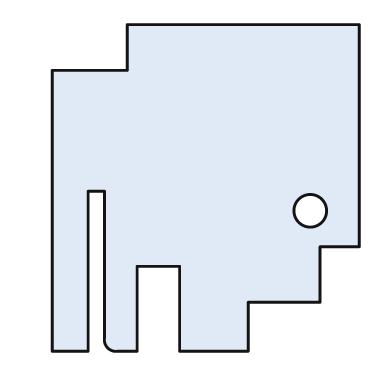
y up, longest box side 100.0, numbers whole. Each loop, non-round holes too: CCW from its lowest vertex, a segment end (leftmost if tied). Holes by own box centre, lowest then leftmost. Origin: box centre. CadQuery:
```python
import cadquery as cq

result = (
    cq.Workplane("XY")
    .moveTo(-47.0, -50.0)
    .lineTo(-36.0, -50.0)
    .lineTo(-36.0, -1.0)
    .lineTo(-31.0, -1.0)
    .lineTo(-31.0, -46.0)
    .threePointArc((-30.0, -49.0), (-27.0, -50.0))
    .lineTo(-21.0, -50.0)
    .lineTo(-21.0, -24.0)
    .lineTo(-8.0, -24.0)
    .lineTo(-8.0, -50.0)
    .lineTo(13.0, -50.0)
    .lineTo(13.0, -35.0)
    .lineTo(35.0, -35.0)
    .lineTo(35.0, -18.0)
    .lineTo(47.0, -18.0)
    .lineTo(47.0, 50.0)
    .lineTo(-24.0, 50.0)
    .lineTo(-24.0, 36.0)
    .lineTo(-47.0, 36.0)
    .close()
    .moveTo(32.0, -7.0)
    .circle(5.0)
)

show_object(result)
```